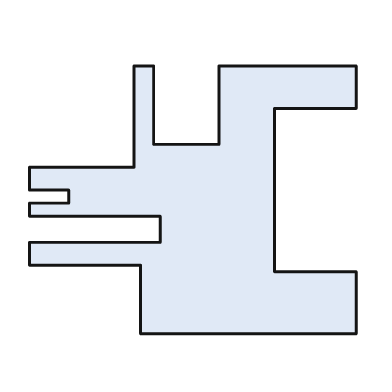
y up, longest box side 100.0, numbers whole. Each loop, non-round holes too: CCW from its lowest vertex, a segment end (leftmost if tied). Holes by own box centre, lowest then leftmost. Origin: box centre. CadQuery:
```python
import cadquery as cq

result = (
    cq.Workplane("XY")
    .moveTo(-16.0, -41.0)
    .lineTo(50.0, -41.0)
    .lineTo(50.0, -22.0)
    .lineTo(25.0, -22.0)
    .lineTo(25.0, 28.0)
    .lineTo(50.0, 28.0)
    .lineTo(50.0, 41.0)
    .lineTo(8.0, 41.0)
    .lineTo(8.0, 17.0)
    .lineTo(-12.0, 17.0)
    .lineTo(-12.0, 41.0)
    .lineTo(-18.0, 41.0)
    .lineTo(-18.0, 10.0)
    .lineTo(-50.0, 10.0)
    .lineTo(-50.0, 3.0)
    .lineTo(-38.0, 3.0)
    .lineTo(-38.0, -1.0)
    .lineTo(-50.0, -1.0)
    .lineTo(-50.0, -5.0)
    .lineTo(-10.0, -5.0)
    .lineTo(-10.0, -13.0)
    .lineTo(-50.0, -13.0)
    .lineTo(-50.0, -20.0)
    .lineTo(-16.0, -20.0)
    .close()
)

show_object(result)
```